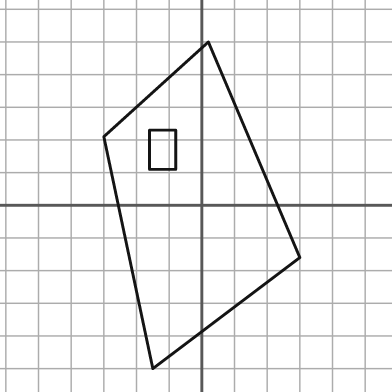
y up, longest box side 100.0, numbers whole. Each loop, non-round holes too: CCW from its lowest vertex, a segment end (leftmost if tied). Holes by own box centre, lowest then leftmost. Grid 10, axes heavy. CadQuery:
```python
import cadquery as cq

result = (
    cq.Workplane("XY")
    .moveTo(-15.0, -50.0)
    .lineTo(30.0, -16.0)
    .lineTo(2.0, 50.0)
    .lineTo(-30.0, 21.0)
    .close()
    .moveTo(-16.0, 11.0)
    .lineTo(-8.0, 11.0)
    .lineTo(-8.0, 23.0)
    .lineTo(-16.0, 23.0)
    .close()
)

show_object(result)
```